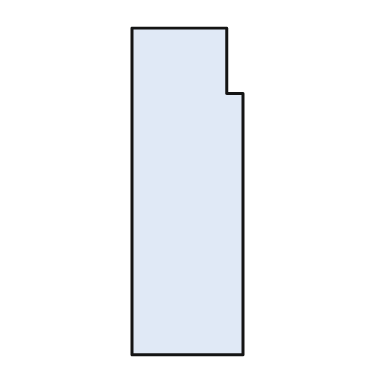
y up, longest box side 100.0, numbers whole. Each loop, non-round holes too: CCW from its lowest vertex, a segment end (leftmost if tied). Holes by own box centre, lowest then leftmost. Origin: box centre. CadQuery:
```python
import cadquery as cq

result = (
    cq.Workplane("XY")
    .moveTo(-17.0, -50.0)
    .lineTo(17.0, -50.0)
    .lineTo(17.0, 30.0)
    .lineTo(12.0, 30.0)
    .lineTo(12.0, 50.0)
    .lineTo(-17.0, 50.0)
    .close()
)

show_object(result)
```